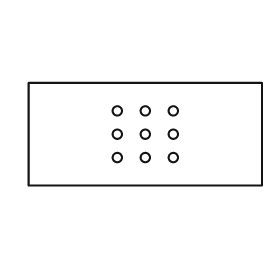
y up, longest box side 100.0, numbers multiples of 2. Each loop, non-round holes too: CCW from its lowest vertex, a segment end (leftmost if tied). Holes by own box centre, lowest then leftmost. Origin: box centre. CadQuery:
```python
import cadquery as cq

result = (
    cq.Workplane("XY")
    .moveTo(-50.0, -22.0)
    .lineTo(50.0, -22.0)
    .lineTo(50.0, 22.0)
    .lineTo(-50.0, 22.0)
    .close()
    .moveTo(-12.0, -10.0)
    .circle(2.0)
    .moveTo(0.0, -10.0)
    .circle(2.0)
    .moveTo(12.0, -10.0)
    .circle(2.0)
    .moveTo(-12.0, 0.0)
    .circle(2.0)
    .moveTo(0.0, 0.0)
    .circle(2.0)
    .moveTo(12.0, 0.0)
    .circle(2.0)
    .moveTo(-12.0, 10.0)
    .circle(2.0)
    .moveTo(0.0, 10.0)
    .circle(2.0)
    .moveTo(12.0, 10.0)
    .circle(2.0)
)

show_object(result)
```